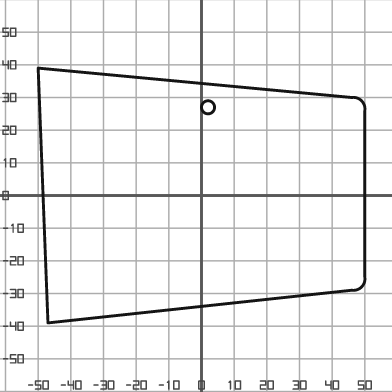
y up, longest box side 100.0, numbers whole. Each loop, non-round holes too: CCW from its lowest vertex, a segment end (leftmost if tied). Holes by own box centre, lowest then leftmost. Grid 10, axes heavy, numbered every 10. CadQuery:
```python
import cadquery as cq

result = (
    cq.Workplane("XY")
    .moveTo(-47.0, -39.0)
    .lineTo(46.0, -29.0)
    .threePointArc((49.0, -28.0), (50.0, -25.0))
    .lineTo(50.0, 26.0)
    .threePointArc((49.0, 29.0), (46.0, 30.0))
    .lineTo(-50.0, 39.0)
    .close()
    .moveTo(2.0, 27.0)
    .circle(2.0)
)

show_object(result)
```